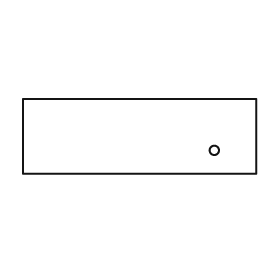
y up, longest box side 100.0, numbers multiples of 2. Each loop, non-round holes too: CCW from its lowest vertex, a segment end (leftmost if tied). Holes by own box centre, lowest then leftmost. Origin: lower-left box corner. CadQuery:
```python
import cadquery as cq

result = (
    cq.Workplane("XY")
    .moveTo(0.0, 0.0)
    .lineTo(100.0, 0.0)
    .lineTo(100.0, 32.0)
    .lineTo(0.0, 32.0)
    .close()
    .moveTo(82.0, 10.0)
    .circle(2.0)
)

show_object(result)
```